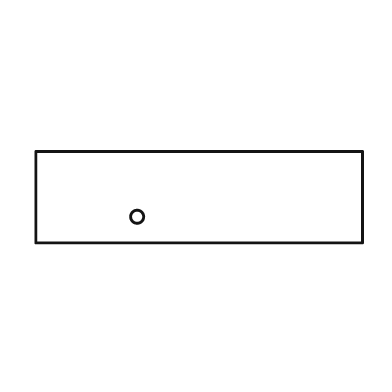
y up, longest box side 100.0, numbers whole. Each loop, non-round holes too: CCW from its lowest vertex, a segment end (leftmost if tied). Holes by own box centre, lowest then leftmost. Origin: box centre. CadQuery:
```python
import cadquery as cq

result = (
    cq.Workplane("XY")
    .moveTo(-50.0, -14.0)
    .lineTo(50.0, -14.0)
    .lineTo(50.0, 14.0)
    .lineTo(-50.0, 14.0)
    .close()
    .moveTo(-19.0, -6.0)
    .circle(2.0)
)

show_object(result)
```